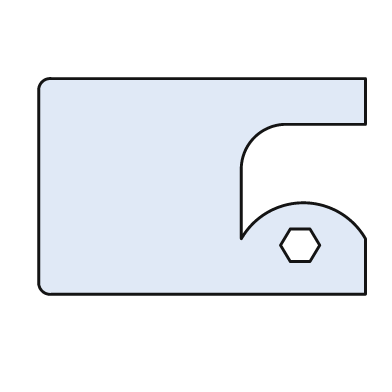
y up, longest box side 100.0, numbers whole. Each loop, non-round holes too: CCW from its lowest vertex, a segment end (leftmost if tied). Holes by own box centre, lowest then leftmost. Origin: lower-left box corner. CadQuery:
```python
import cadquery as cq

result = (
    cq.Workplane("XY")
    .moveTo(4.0, 0.0)
    .lineTo(100.0, 0.0)
    .lineTo(100.0, 17.0)
    .threePointArc((81.0, 28.0), (62.0, 17.0))
    .lineTo(62.0, 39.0)
    .threePointArc((66.0, 48.0), (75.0, 52.0))
    .lineTo(100.0, 52.0)
    .lineTo(100.0, 66.0)
    .lineTo(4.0, 66.0)
    .threePointArc((1.0, 65.0), (0.0, 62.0))
    .lineTo(0.0, 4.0)
    .threePointArc((1.0, 1.0), (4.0, 0.0))
    .close()
    .moveTo(77.0, 10.0)
    .lineTo(83.0, 10.0)
    .lineTo(86.0, 15.0)
    .lineTo(83.0, 20.0)
    .lineTo(77.0, 20.0)
    .lineTo(74.0, 15.0)
    .close()
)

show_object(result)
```